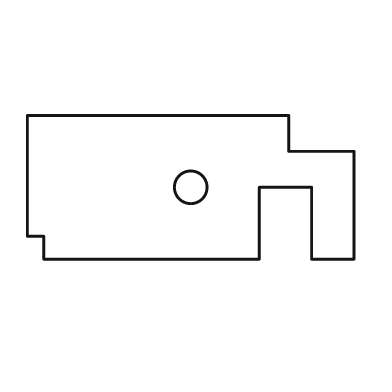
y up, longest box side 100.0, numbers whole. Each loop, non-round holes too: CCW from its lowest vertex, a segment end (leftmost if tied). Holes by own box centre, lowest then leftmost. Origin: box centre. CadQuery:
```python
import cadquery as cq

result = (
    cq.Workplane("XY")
    .moveTo(-45.0, -22.0)
    .lineTo(21.0, -22.0)
    .lineTo(21.0, 0.0)
    .lineTo(37.0, 0.0)
    .lineTo(37.0, -22.0)
    .lineTo(50.0, -22.0)
    .lineTo(50.0, 11.0)
    .lineTo(30.0, 11.0)
    .lineTo(30.0, 22.0)
    .lineTo(-50.0, 22.0)
    .lineTo(-50.0, -15.0)
    .lineTo(-45.0, -15.0)
    .close()
    .moveTo(0.0, 0.0)
    .circle(5.0)
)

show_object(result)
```